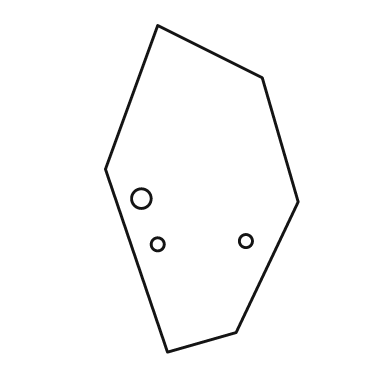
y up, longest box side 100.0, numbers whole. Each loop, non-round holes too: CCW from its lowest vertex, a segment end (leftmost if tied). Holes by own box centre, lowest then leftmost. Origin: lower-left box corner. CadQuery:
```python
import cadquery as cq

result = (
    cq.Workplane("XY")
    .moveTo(19.0, 0.0)
    .lineTo(40.0, 6.0)
    .lineTo(59.0, 46.0)
    .lineTo(48.0, 84.0)
    .lineTo(16.0, 100.0)
    .lineTo(0.0, 56.0)
    .close()
    .moveTo(16.0, 33.0)
    .circle(2.0)
    .moveTo(43.0, 34.0)
    .circle(2.0)
    .moveTo(11.0, 47.0)
    .circle(3.0)
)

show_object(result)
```